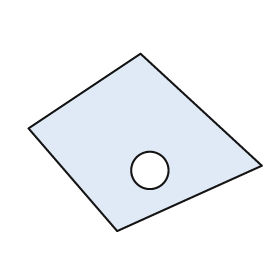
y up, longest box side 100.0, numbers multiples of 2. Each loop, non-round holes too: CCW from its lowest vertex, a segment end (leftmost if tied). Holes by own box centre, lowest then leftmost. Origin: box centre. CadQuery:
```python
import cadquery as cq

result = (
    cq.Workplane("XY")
    .moveTo(-12.0, -38.0)
    .lineTo(50.0, -10.0)
    .lineTo(-2.0, 38.0)
    .lineTo(-50.0, 6.0)
    .close()
    .moveTo(2.0, -12.0)
    .circle(8.0)
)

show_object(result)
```